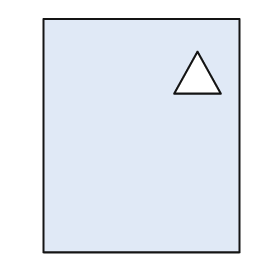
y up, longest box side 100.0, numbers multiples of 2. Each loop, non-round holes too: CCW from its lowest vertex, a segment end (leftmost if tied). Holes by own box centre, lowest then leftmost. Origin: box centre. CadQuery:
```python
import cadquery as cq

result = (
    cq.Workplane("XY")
    .moveTo(-42.0, -50.0)
    .lineTo(42.0, -50.0)
    .lineTo(42.0, 50.0)
    .lineTo(-42.0, 50.0)
    .close()
    .moveTo(14.0, 18.0)
    .lineTo(34.0, 18.0)
    .lineTo(24.0, 36.0)
    .close()
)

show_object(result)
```